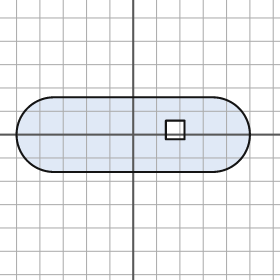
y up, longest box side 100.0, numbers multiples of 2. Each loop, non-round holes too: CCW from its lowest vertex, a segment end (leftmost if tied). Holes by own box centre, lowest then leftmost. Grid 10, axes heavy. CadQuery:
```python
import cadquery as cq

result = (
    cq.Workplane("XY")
    .moveTo(-34.0, -16.0)
    .lineTo(34.0, -16.0)
    .threePointArc((50.0, 0.0), (34.0, 16.0))
    .lineTo(-34.0, 16.0)
    .threePointArc((-50.0, 0.0), (-34.0, -16.0))
    .close()
    .moveTo(14.0, -2.0)
    .lineTo(22.0, -2.0)
    .lineTo(22.0, 6.0)
    .lineTo(14.0, 6.0)
    .close()
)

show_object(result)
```